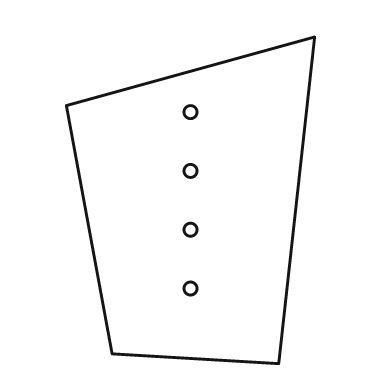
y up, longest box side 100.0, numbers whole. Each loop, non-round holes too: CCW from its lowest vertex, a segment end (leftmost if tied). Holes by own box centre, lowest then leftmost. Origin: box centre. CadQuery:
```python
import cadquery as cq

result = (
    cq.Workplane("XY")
    .moveTo(27.0, -50.0)
    .lineTo(38.0, 50.0)
    .lineTo(-38.0, 29.0)
    .lineTo(-24.0, -47.0)
    .close()
    .moveTo(0.0, -27.0)
    .circle(2.0)
    .moveTo(0.0, -9.0)
    .circle(2.0)
    .moveTo(0.0, 9.0)
    .circle(2.0)
    .moveTo(0.0, 27.0)
    .circle(2.0)
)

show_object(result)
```